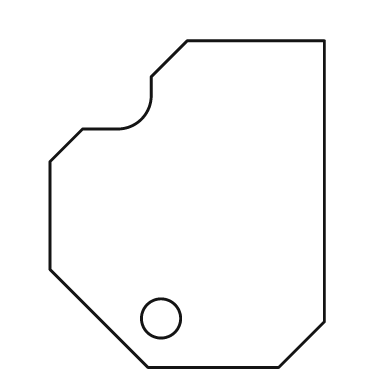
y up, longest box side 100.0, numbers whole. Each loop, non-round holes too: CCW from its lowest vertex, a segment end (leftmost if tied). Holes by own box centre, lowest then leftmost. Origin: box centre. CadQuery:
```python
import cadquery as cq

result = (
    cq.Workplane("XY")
    .moveTo(-12.0, -50.0)
    .lineTo(28.0, -50.0)
    .lineTo(42.0, -36.0)
    .lineTo(42.0, 50.0)
    .lineTo(0.0, 50.0)
    .lineTo(-11.0, 39.0)
    .lineTo(-11.0, 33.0)
    .threePointArc((-14.0, 26.0), (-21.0, 23.0))
    .lineTo(-32.0, 23.0)
    .lineTo(-42.0, 13.0)
    .lineTo(-42.0, -20.0)
    .close()
    .moveTo(-8.0, -35.0)
    .circle(6.0)
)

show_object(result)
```